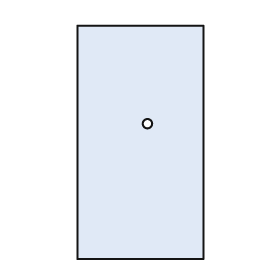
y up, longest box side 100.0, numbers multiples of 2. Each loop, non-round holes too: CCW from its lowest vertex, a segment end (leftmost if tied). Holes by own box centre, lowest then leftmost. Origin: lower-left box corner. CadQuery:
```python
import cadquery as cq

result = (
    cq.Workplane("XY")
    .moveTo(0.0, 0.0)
    .lineTo(54.0, 0.0)
    .lineTo(54.0, 100.0)
    .lineTo(0.0, 100.0)
    .close()
    .moveTo(30.0, 58.0)
    .circle(2.0)
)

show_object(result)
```